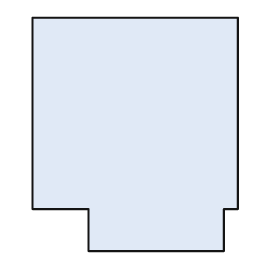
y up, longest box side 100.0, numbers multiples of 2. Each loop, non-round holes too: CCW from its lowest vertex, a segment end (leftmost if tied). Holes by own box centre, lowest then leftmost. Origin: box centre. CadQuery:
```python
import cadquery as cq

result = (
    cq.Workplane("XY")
    .moveTo(-20.0, -50.0)
    .lineTo(38.0, -50.0)
    .lineTo(38.0, -32.0)
    .lineTo(44.0, -32.0)
    .lineTo(44.0, 50.0)
    .lineTo(-44.0, 50.0)
    .lineTo(-44.0, -32.0)
    .lineTo(-20.0, -32.0)
    .close()
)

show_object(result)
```